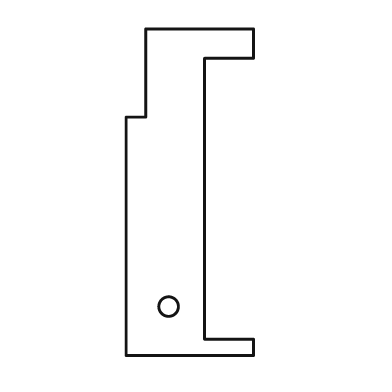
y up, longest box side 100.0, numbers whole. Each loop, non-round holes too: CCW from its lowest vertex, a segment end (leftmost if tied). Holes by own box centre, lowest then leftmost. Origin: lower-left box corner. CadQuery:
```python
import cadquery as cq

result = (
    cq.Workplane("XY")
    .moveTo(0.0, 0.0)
    .lineTo(39.0, 0.0)
    .lineTo(39.0, 5.0)
    .lineTo(24.0, 5.0)
    .lineTo(24.0, 91.0)
    .lineTo(39.0, 91.0)
    .lineTo(39.0, 100.0)
    .lineTo(6.0, 100.0)
    .lineTo(6.0, 73.0)
    .lineTo(0.0, 73.0)
    .close()
    .moveTo(13.0, 15.0)
    .circle(3.0)
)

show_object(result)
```